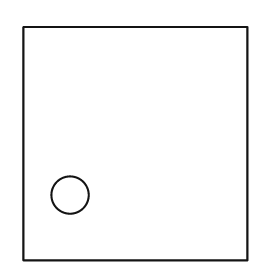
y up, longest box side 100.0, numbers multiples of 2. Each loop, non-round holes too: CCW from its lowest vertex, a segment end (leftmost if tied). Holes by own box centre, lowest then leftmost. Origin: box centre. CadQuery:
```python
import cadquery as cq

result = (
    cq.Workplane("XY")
    .moveTo(-48.0, -50.0)
    .lineTo(48.0, -50.0)
    .lineTo(48.0, 50.0)
    .lineTo(-48.0, 50.0)
    .close()
    .moveTo(-28.0, -22.0)
    .circle(8.0)
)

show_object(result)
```